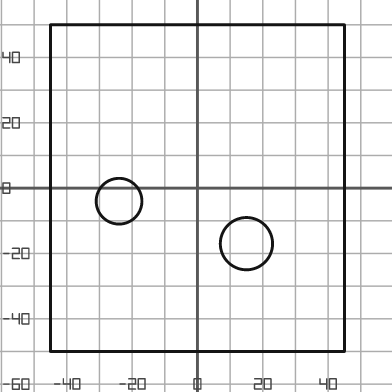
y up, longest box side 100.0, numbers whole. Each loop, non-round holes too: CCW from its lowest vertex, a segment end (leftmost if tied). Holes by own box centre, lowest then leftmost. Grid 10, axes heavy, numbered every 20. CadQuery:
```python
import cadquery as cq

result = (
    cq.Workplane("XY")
    .moveTo(-45.0, -50.0)
    .lineTo(45.0, -50.0)
    .lineTo(45.0, 50.0)
    .lineTo(-45.0, 50.0)
    .close()
    .moveTo(15.0, -17.0)
    .circle(8.0)
    .moveTo(-24.0, -4.0)
    .circle(7.0)
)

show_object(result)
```